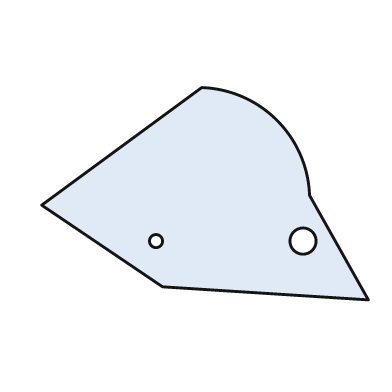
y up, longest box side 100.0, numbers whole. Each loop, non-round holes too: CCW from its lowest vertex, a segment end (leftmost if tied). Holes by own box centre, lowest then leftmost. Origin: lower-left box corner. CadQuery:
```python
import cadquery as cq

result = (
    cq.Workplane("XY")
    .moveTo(100.0, 0.0)
    .lineTo(82.0, 32.0)
    .threePointArc((72.0, 55.0), (49.0, 65.0))
    .lineTo(0.0, 29.0)
    .lineTo(37.0, 4.0)
    .close()
    .moveTo(35.0, 18.0)
    .circle(2.0)
    .moveTo(80.0, 18.0)
    .circle(4.0)
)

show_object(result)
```